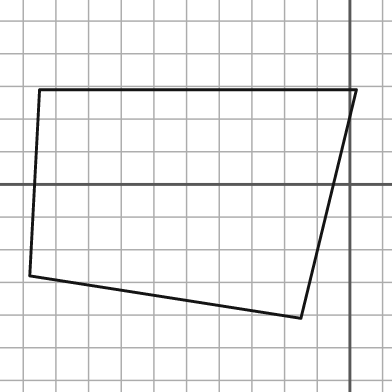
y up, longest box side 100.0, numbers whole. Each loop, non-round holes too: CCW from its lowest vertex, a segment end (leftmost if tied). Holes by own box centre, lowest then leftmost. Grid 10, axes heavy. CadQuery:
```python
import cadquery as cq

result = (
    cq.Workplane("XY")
    .moveTo(-15.0, -41.0)
    .lineTo(2.0, 29.0)
    .lineTo(-95.0, 29.0)
    .lineTo(-98.0, -28.0)
    .close()
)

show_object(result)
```